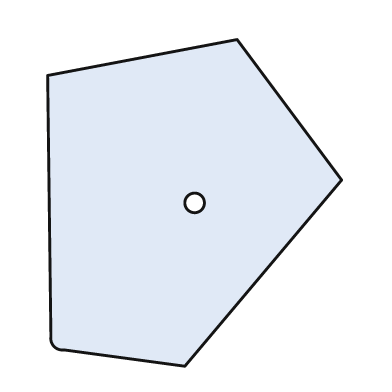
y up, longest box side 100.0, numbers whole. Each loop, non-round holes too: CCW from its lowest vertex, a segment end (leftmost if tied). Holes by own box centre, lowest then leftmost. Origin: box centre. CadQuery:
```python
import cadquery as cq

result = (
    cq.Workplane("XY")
    .moveTo(-3.0, -50.0)
    .lineTo(45.0, 7.0)
    .lineTo(13.0, 50.0)
    .lineTo(-45.0, 39.0)
    .lineTo(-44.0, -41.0)
    .threePointArc((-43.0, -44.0), (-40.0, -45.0))
    .close()
    .moveTo(0.0, 0.0)
    .circle(3.0)
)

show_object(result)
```